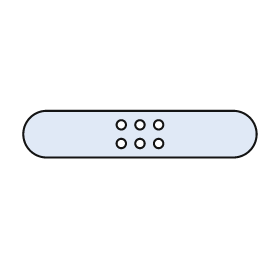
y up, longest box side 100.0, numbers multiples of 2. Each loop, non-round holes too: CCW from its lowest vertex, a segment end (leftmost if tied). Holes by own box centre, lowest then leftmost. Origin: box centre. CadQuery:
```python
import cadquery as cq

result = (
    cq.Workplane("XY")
    .moveTo(-40.0, -10.0)
    .lineTo(40.0, -10.0)
    .threePointArc((50.0, 0.0), (40.0, 10.0))
    .lineTo(-40.0, 10.0)
    .threePointArc((-50.0, 0.0), (-40.0, -10.0))
    .close()
    .moveTo(-8.0, -4.0)
    .circle(2.0)
    .moveTo(0.0, -4.0)
    .circle(2.0)
    .moveTo(8.0, -4.0)
    .circle(2.0)
    .moveTo(-8.0, 4.0)
    .circle(2.0)
    .moveTo(0.0, 4.0)
    .circle(2.0)
    .moveTo(8.0, 4.0)
    .circle(2.0)
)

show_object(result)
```